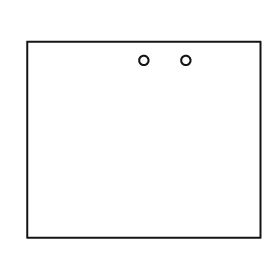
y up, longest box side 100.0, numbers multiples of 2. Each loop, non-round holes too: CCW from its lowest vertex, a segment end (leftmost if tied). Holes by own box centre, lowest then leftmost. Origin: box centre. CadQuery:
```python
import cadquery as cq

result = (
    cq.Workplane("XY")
    .moveTo(-50.0, -42.0)
    .lineTo(50.0, -42.0)
    .lineTo(50.0, 42.0)
    .lineTo(-50.0, 42.0)
    .close()
    .moveTo(0.0, 34.0)
    .circle(2.0)
    .moveTo(18.0, 34.0)
    .circle(2.0)
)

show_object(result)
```